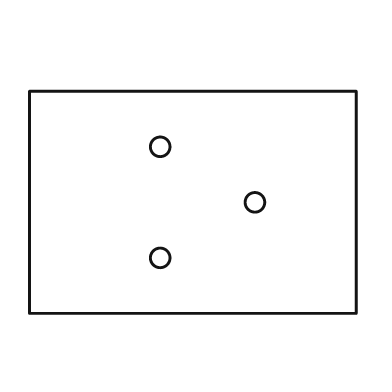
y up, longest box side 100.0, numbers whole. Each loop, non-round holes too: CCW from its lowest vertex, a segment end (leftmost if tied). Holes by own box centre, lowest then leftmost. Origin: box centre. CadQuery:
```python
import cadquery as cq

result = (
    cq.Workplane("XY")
    .moveTo(-50.0, -34.0)
    .lineTo(50.0, -34.0)
    .lineTo(50.0, 34.0)
    .lineTo(-50.0, 34.0)
    .close()
    .moveTo(-10.0, -17.0)
    .circle(3.0)
    .moveTo(19.0, 0.0)
    .circle(3.0)
    .moveTo(-10.0, 17.0)
    .circle(3.0)
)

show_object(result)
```